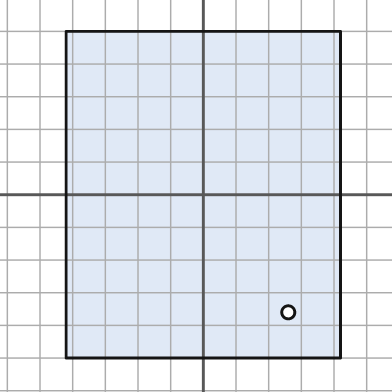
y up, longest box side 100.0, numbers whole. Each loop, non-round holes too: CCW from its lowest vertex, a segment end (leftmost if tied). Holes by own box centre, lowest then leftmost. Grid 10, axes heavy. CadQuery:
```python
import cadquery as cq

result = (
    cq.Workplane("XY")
    .moveTo(-42.0, -50.0)
    .lineTo(42.0, -50.0)
    .lineTo(42.0, 50.0)
    .lineTo(-42.0, 50.0)
    .close()
    .moveTo(26.0, -36.0)
    .circle(2.0)
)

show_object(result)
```